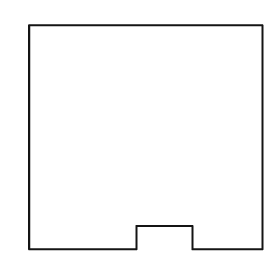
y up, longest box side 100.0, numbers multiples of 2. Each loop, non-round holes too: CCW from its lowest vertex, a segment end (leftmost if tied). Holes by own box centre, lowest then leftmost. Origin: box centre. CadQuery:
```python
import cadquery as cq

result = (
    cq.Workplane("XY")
    .moveTo(-50.0, -48.0)
    .lineTo(-4.0, -48.0)
    .lineTo(-4.0, -38.0)
    .lineTo(20.0, -38.0)
    .lineTo(20.0, -48.0)
    .lineTo(50.0, -48.0)
    .lineTo(50.0, 48.0)
    .lineTo(-50.0, 48.0)
    .close()
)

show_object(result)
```